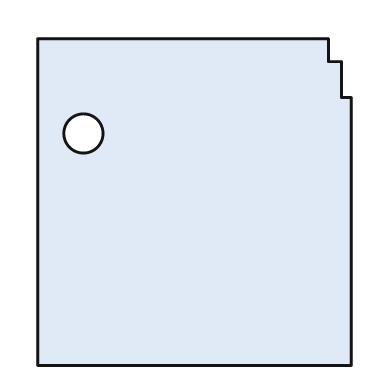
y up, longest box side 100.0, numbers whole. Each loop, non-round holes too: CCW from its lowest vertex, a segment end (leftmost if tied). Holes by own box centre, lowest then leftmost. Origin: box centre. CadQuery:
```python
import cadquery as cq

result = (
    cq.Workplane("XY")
    .moveTo(-48.0, -50.0)
    .lineTo(48.0, -50.0)
    .lineTo(48.0, 32.0)
    .lineTo(45.0, 32.0)
    .lineTo(45.0, 43.0)
    .lineTo(41.0, 43.0)
    .lineTo(41.0, 50.0)
    .lineTo(-48.0, 50.0)
    .close()
    .moveTo(-34.0, 21.0)
    .circle(6.0)
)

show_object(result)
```